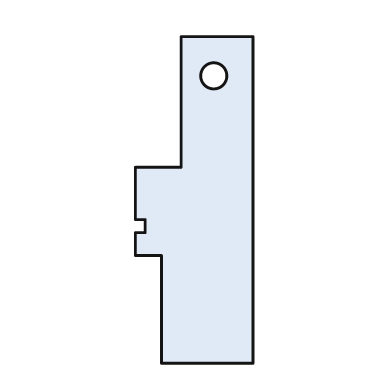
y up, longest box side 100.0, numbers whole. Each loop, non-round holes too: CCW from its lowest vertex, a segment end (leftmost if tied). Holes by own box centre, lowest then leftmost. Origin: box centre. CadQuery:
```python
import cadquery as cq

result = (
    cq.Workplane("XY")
    .moveTo(-10.0, -50.0)
    .lineTo(18.0, -50.0)
    .lineTo(18.0, 50.0)
    .lineTo(-4.0, 50.0)
    .lineTo(-4.0, 10.0)
    .lineTo(-18.0, 10.0)
    .lineTo(-18.0, -6.0)
    .lineTo(-15.0, -6.0)
    .lineTo(-15.0, -10.0)
    .lineTo(-18.0, -10.0)
    .lineTo(-18.0, -17.0)
    .lineTo(-10.0, -17.0)
    .close()
    .moveTo(6.0, 38.0)
    .circle(4.0)
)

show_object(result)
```